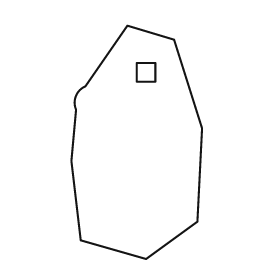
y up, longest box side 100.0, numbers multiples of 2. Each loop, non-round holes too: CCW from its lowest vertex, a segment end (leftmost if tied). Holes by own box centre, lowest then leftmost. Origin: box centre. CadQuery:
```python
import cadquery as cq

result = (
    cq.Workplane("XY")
    .moveTo(4.0, -50.0)
    .lineTo(26.0, -34.0)
    .lineTo(28.0, 6.0)
    .lineTo(16.0, 44.0)
    .lineTo(-4.0, 50.0)
    .lineTo(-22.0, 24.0)
    .threePointArc((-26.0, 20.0), (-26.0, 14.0))
    .lineTo(-28.0, -8.0)
    .lineTo(-24.0, -42.0)
    .close()
    .moveTo(0.0, 26.0)
    .lineTo(8.0, 26.0)
    .lineTo(8.0, 34.0)
    .lineTo(0.0, 34.0)
    .close()
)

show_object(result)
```